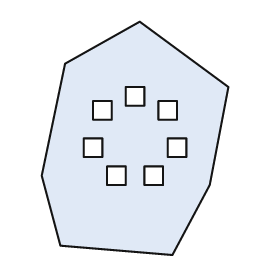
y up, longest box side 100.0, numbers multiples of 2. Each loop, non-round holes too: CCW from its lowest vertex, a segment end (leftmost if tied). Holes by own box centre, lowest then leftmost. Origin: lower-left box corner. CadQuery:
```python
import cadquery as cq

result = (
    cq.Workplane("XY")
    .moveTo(56.0, 0.0)
    .lineTo(72.0, 30.0)
    .lineTo(80.0, 72.0)
    .lineTo(42.0, 100.0)
    .lineTo(10.0, 82.0)
    .lineTo(0.0, 34.0)
    .lineTo(8.0, 4.0)
    .close()
    .moveTo(28.0, 30.0)
    .lineTo(36.0, 30.0)
    .lineTo(36.0, 38.0)
    .lineTo(28.0, 38.0)
    .close()
    .moveTo(44.0, 30.0)
    .lineTo(52.0, 30.0)
    .lineTo(52.0, 38.0)
    .lineTo(44.0, 38.0)
    .close()
    .moveTo(18.0, 42.0)
    .lineTo(26.0, 42.0)
    .lineTo(26.0, 50.0)
    .lineTo(18.0, 50.0)
    .close()
    .moveTo(54.0, 42.0)
    .lineTo(62.0, 42.0)
    .lineTo(62.0, 50.0)
    .lineTo(54.0, 50.0)
    .close()
    .moveTo(22.0, 58.0)
    .lineTo(30.0, 58.0)
    .lineTo(30.0, 66.0)
    .lineTo(22.0, 66.0)
    .close()
    .moveTo(50.0, 58.0)
    .lineTo(58.0, 58.0)
    .lineTo(58.0, 66.0)
    .lineTo(50.0, 66.0)
    .close()
    .moveTo(36.0, 64.0)
    .lineTo(44.0, 64.0)
    .lineTo(44.0, 72.0)
    .lineTo(36.0, 72.0)
    .close()
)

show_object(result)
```